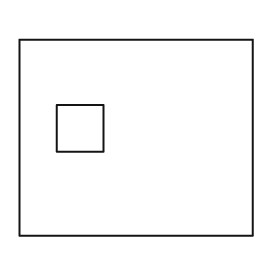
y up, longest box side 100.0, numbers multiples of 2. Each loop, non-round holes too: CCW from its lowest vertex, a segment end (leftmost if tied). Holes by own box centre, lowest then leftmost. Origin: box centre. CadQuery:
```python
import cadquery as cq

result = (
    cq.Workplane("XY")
    .moveTo(-50.0, -42.0)
    .lineTo(50.0, -42.0)
    .lineTo(50.0, 42.0)
    .lineTo(-50.0, 42.0)
    .close()
    .moveTo(-34.0, -6.0)
    .lineTo(-14.0, -6.0)
    .lineTo(-14.0, 14.0)
    .lineTo(-34.0, 14.0)
    .close()
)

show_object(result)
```